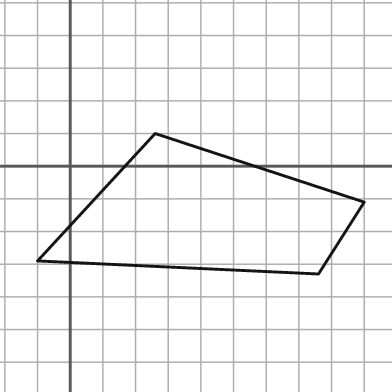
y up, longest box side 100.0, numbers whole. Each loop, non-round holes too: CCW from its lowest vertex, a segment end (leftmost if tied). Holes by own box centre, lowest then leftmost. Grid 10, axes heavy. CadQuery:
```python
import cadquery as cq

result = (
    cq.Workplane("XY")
    .moveTo(76.0, -33.0)
    .lineTo(90.0, -11.0)
    .lineTo(26.0, 10.0)
    .lineTo(-10.0, -29.0)
    .close()
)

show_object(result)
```